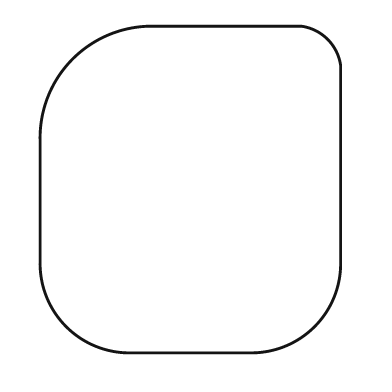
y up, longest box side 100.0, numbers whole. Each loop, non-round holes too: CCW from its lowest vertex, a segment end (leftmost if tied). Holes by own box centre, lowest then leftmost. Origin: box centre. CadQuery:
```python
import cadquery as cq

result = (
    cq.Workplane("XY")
    .moveTo(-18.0, -50.0)
    .lineTo(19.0, -50.0)
    .threePointArc((38.0, -42.0), (46.0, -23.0))
    .lineTo(46.0, 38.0)
    .threePointArc((42.0, 46.0), (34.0, 50.0))
    .lineTo(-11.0, 50.0)
    .threePointArc((-36.0, 40.0), (-46.0, 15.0))
    .lineTo(-46.0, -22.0)
    .threePointArc((-38.0, -42.0), (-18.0, -50.0))
    .close()
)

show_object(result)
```